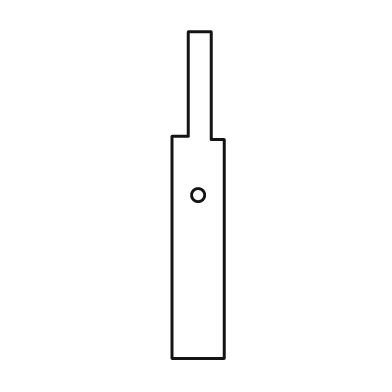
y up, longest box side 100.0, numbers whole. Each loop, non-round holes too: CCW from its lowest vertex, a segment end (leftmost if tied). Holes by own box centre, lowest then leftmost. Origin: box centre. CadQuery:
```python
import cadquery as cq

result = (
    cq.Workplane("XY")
    .moveTo(-8.0, -50.0)
    .lineTo(8.0, -50.0)
    .lineTo(8.0, 17.0)
    .lineTo(4.0, 17.0)
    .lineTo(4.0, 50.0)
    .lineTo(-3.0, 50.0)
    .lineTo(-3.0, 18.0)
    .lineTo(-8.0, 18.0)
    .close()
    .moveTo(0.0, 0.0)
    .circle(2.0)
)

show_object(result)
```